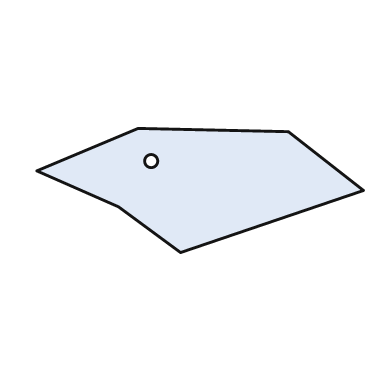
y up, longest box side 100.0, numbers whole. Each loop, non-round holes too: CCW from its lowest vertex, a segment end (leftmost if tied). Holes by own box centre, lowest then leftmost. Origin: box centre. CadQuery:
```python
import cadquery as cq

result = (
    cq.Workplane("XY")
    .moveTo(-6.0, -19.0)
    .lineTo(50.0, 0.0)
    .lineTo(27.0, 18.0)
    .lineTo(-19.0, 19.0)
    .lineTo(-50.0, 6.0)
    .lineTo(-25.0, -5.0)
    .close()
    .moveTo(-15.0, 9.0)
    .circle(2.0)
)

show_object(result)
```